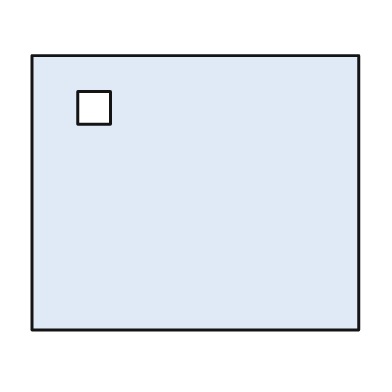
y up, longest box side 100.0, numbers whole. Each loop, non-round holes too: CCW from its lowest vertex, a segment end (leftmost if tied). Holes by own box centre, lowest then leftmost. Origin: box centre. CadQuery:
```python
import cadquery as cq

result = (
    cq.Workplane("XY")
    .moveTo(-50.0, -42.0)
    .lineTo(50.0, -42.0)
    .lineTo(50.0, 42.0)
    .lineTo(-50.0, 42.0)
    .close()
    .moveTo(-36.0, 21.0)
    .lineTo(-26.0, 21.0)
    .lineTo(-26.0, 31.0)
    .lineTo(-36.0, 31.0)
    .close()
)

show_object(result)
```